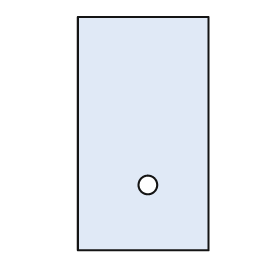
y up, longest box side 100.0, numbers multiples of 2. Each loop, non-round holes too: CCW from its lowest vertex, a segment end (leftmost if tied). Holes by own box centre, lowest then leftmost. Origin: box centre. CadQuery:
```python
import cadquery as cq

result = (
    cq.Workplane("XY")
    .moveTo(-28.0, -50.0)
    .lineTo(28.0, -50.0)
    .lineTo(28.0, 50.0)
    .lineTo(-28.0, 50.0)
    .close()
    .moveTo(2.0, -22.0)
    .circle(4.0)
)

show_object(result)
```